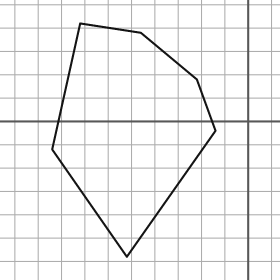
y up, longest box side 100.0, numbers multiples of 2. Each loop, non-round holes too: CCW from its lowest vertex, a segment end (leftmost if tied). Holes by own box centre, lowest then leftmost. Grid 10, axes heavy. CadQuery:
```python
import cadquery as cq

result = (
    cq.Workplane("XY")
    .moveTo(-52.0, -58.0)
    .lineTo(-14.0, -4.0)
    .lineTo(-22.0, 18.0)
    .lineTo(-46.0, 38.0)
    .lineTo(-72.0, 42.0)
    .lineTo(-84.0, -12.0)
    .close()
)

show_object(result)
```